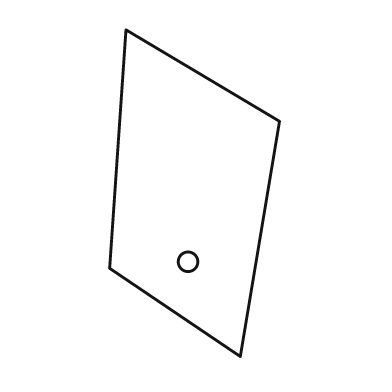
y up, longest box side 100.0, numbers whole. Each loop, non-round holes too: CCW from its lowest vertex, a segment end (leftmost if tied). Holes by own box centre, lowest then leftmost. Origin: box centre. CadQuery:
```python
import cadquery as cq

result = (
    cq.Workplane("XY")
    .moveTo(14.0, -50.0)
    .lineTo(26.0, 22.0)
    .lineTo(-21.0, 50.0)
    .lineTo(-26.0, -23.0)
    .close()
    .moveTo(-2.0, -21.0)
    .circle(3.0)
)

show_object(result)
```